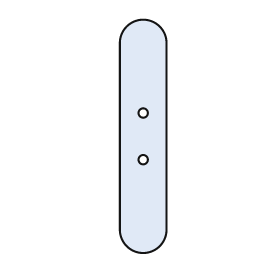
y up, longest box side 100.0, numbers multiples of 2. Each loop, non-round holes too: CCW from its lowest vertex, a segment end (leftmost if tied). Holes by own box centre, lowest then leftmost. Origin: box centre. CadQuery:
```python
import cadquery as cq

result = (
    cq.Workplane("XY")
    .moveTo(-10.0, -40.0)
    .threePointArc((0.0, -50.0), (10.0, -40.0))
    .lineTo(10.0, 40.0)
    .threePointArc((0.0, 50.0), (-10.0, 40.0))
    .close()
    .moveTo(0.0, -10.0)
    .circle(2.0)
    .moveTo(0.0, 10.0)
    .circle(2.0)
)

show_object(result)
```